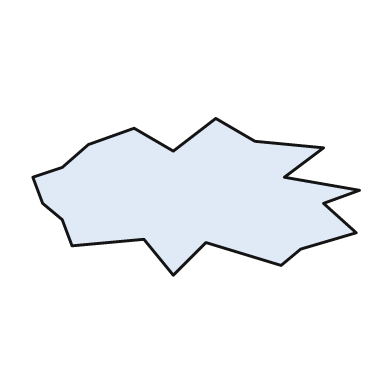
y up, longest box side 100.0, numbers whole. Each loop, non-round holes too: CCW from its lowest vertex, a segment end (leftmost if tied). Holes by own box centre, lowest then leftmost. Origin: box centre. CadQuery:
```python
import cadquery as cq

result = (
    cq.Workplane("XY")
    .moveTo(-7.0, -24.0)
    .lineTo(3.0, -14.0)
    .lineTo(26.0, -21.0)
    .lineTo(32.0, -16.0)
    .lineTo(49.0, -11.0)
    .lineTo(39.0, -2.0)
    .lineTo(50.0, 2.0)
    .lineTo(27.0, 6.0)
    .lineTo(39.0, 15.0)
    .lineTo(18.0, 17.0)
    .lineTo(6.0, 24.0)
    .lineTo(-7.0, 14.0)
    .lineTo(-19.0, 21.0)
    .lineTo(-33.0, 16.0)
    .lineTo(-41.0, 9.0)
    .lineTo(-50.0, 6.0)
    .lineTo(-47.0, -2.0)
    .lineTo(-41.0, -7.0)
    .lineTo(-38.0, -15.0)
    .lineTo(-16.0, -13.0)
    .close()
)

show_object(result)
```